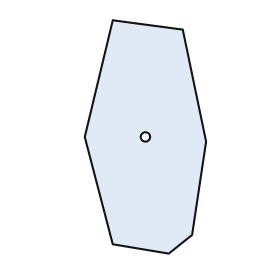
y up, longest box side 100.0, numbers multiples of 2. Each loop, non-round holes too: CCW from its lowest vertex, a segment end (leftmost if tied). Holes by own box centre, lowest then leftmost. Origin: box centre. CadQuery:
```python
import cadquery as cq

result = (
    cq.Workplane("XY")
    .moveTo(10.0, -50.0)
    .lineTo(20.0, -42.0)
    .lineTo(26.0, -2.0)
    .lineTo(16.0, 46.0)
    .lineTo(-14.0, 50.0)
    .lineTo(-26.0, 0.0)
    .lineTo(-14.0, -46.0)
    .close()
    .moveTo(0.0, 0.0)
    .circle(2.0)
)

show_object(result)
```